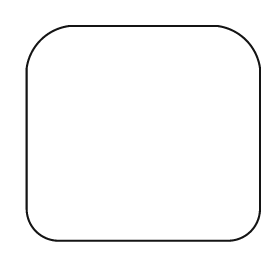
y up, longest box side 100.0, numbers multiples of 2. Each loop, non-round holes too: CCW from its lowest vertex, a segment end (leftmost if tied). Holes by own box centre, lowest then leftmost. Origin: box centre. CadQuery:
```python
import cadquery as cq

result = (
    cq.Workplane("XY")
    .moveTo(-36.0, -46.0)
    .lineTo(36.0, -46.0)
    .threePointArc((46.0, -42.0), (50.0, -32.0))
    .lineTo(50.0, 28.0)
    .threePointArc((44.0, 40.0), (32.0, 46.0))
    .lineTo(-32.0, 46.0)
    .threePointArc((-44.0, 40.0), (-50.0, 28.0))
    .lineTo(-50.0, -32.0)
    .threePointArc((-46.0, -42.0), (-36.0, -46.0))
    .close()
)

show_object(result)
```